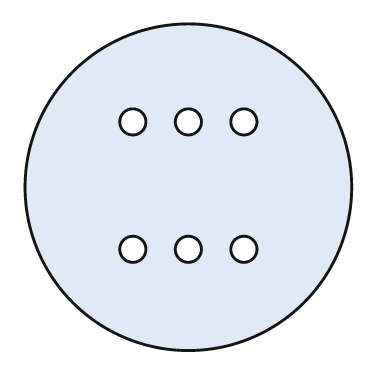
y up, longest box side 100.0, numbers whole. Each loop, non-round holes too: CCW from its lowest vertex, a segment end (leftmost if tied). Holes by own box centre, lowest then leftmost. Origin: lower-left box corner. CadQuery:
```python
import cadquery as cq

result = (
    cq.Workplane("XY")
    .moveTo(50.0, 50.0)
    .circle(50.0)
    .moveTo(33.0, 31.0)
    .circle(4.0)
    .moveTo(50.0, 31.0)
    .circle(4.0)
    .moveTo(67.0, 31.0)
    .circle(4.0)
    .moveTo(33.0, 70.0)
    .circle(4.0)
    .moveTo(50.0, 70.0)
    .circle(4.0)
    .moveTo(67.0, 70.0)
    .circle(4.0)
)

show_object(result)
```